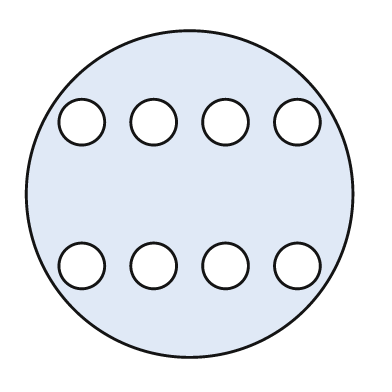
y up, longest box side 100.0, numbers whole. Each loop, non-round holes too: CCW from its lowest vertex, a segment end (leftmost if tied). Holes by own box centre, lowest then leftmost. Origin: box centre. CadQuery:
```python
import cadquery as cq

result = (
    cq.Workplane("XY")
    .moveTo(0.0, 0.0)
    .circle(50.0)
    .moveTo(-33.0, -22.0)
    .circle(7.0)
    .moveTo(-11.0, -22.0)
    .circle(7.0)
    .moveTo(11.0, -22.0)
    .circle(7.0)
    .moveTo(33.0, -22.0)
    .circle(7.0)
    .moveTo(-33.0, 22.0)
    .circle(7.0)
    .moveTo(-11.0, 22.0)
    .circle(7.0)
    .moveTo(11.0, 22.0)
    .circle(7.0)
    .moveTo(33.0, 22.0)
    .circle(7.0)
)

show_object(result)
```